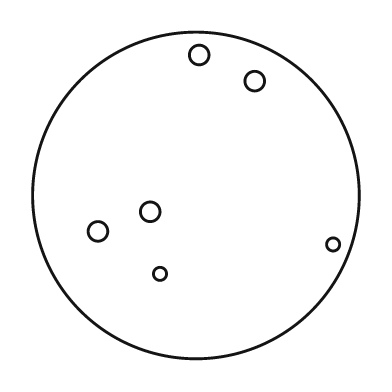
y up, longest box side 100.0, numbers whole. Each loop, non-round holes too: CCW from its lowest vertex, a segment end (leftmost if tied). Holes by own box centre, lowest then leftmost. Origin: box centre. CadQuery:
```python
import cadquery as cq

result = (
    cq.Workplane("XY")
    .moveTo(0.0, 0.0)
    .circle(50.0)
    .moveTo(-11.0, -24.0)
    .circle(2.0)
    .moveTo(42.0, -15.0)
    .circle(2.0)
    .moveTo(-30.0, -11.0)
    .circle(3.0)
    .moveTo(-14.0, -5.0)
    .circle(3.0)
    .moveTo(18.0, 35.0)
    .circle(3.0)
    .moveTo(1.0, 43.0)
    .circle(3.0)
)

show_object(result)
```